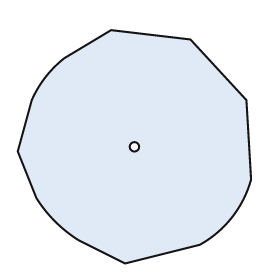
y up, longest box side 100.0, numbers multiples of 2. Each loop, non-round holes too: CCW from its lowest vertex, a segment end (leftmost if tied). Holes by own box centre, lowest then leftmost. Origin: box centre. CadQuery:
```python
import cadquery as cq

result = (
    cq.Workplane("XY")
    .moveTo(-4.0, -50.0)
    .lineTo(28.0, -42.0)
    .threePointArc((42.0, -30.0), (50.0, -14.0))
    .lineTo(48.0, 20.0)
    .lineTo(24.0, 46.0)
    .lineTo(-10.0, 50.0)
    .lineTo(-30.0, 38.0)
    .threePointArc((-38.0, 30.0), (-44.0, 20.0))
    .lineTo(-50.0, -2.0)
    .lineTo(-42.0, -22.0)
    .threePointArc((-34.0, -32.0), (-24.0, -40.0))
    .close()
    .moveTo(0.0, 0.0)
    .circle(2.0)
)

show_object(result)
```